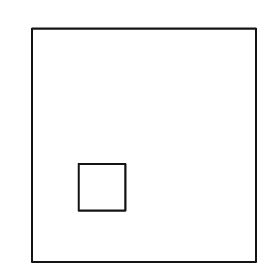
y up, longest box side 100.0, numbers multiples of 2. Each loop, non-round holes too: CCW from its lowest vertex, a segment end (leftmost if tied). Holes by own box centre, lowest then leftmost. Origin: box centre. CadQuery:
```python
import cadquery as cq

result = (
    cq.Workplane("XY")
    .moveTo(-48.0, -50.0)
    .lineTo(48.0, -50.0)
    .lineTo(48.0, 50.0)
    .lineTo(-48.0, 50.0)
    .close()
    .moveTo(-28.0, -28.0)
    .lineTo(-8.0, -28.0)
    .lineTo(-8.0, -8.0)
    .lineTo(-28.0, -8.0)
    .close()
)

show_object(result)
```